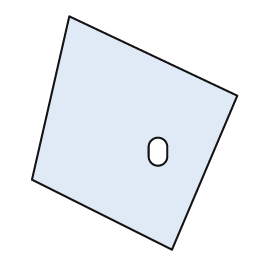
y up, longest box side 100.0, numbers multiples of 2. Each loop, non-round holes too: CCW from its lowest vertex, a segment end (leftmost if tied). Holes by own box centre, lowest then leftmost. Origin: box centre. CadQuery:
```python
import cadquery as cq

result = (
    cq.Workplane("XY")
    .moveTo(16.0, -50.0)
    .lineTo(44.0, 16.0)
    .lineTo(-28.0, 50.0)
    .lineTo(-44.0, -20.0)
    .close()
    .moveTo(6.0, -10.0)
    .threePointArc((10.0, -14.0), (14.0, -10.0))
    .lineTo(14.0, -6.0)
    .threePointArc((10.0, -2.0), (6.0, -6.0))
    .close()
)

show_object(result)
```